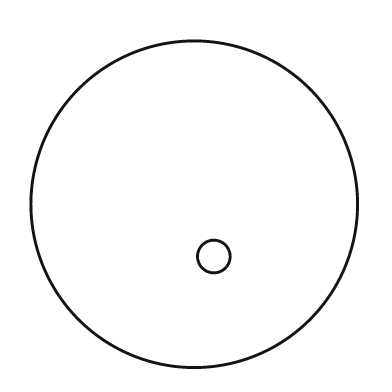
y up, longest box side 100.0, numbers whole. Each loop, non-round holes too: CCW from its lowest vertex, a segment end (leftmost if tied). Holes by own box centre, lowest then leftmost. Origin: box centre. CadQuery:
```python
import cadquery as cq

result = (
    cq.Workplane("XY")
    .moveTo(0.0, 0.0)
    .circle(50.0)
    .moveTo(6.0, -16.0)
    .circle(5.0)
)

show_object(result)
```